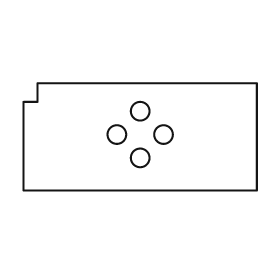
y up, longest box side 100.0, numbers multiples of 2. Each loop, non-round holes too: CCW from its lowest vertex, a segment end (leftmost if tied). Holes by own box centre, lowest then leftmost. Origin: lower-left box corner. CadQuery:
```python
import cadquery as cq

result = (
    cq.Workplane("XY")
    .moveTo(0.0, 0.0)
    .lineTo(100.0, 0.0)
    .lineTo(100.0, 46.0)
    .lineTo(6.0, 46.0)
    .lineTo(6.0, 38.0)
    .lineTo(0.0, 38.0)
    .close()
    .moveTo(50.0, 14.0)
    .circle(4.0)
    .moveTo(40.0, 24.0)
    .circle(4.0)
    .moveTo(60.0, 24.0)
    .circle(4.0)
    .moveTo(50.0, 34.0)
    .circle(4.0)
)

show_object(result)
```